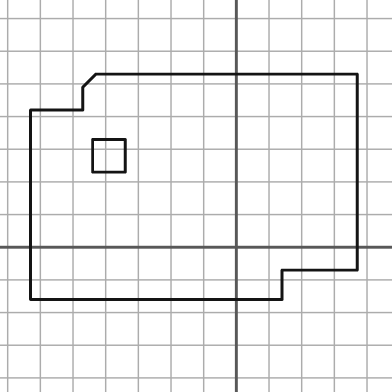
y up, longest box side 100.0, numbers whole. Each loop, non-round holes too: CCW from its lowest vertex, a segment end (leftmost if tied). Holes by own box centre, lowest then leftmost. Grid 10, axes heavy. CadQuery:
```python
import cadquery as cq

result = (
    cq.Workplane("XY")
    .moveTo(-63.0, -16.0)
    .lineTo(14.0, -16.0)
    .lineTo(14.0, -7.0)
    .lineTo(37.0, -7.0)
    .lineTo(37.0, 53.0)
    .lineTo(-43.0, 53.0)
    .lineTo(-47.0, 49.0)
    .lineTo(-47.0, 42.0)
    .lineTo(-63.0, 42.0)
    .close()
    .moveTo(-44.0, 23.0)
    .lineTo(-34.0, 23.0)
    .lineTo(-34.0, 33.0)
    .lineTo(-44.0, 33.0)
    .close()
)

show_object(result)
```